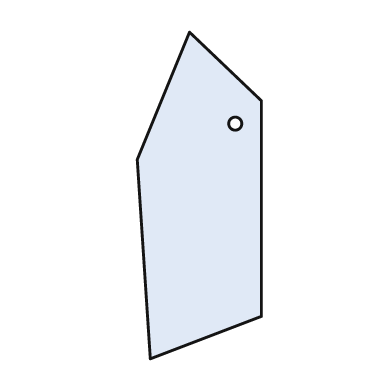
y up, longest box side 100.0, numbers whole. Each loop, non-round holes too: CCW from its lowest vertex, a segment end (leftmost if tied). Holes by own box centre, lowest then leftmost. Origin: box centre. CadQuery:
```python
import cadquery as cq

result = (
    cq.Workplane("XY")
    .moveTo(-15.0, -50.0)
    .lineTo(19.0, -37.0)
    .lineTo(19.0, 29.0)
    .lineTo(-3.0, 50.0)
    .lineTo(-19.0, 11.0)
    .close()
    .moveTo(11.0, 22.0)
    .circle(2.0)
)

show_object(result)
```